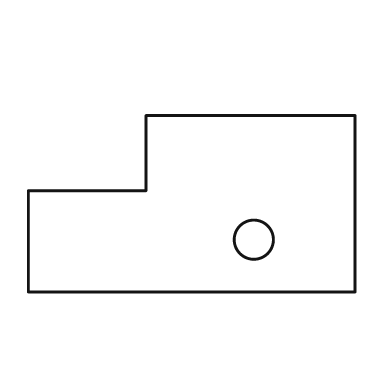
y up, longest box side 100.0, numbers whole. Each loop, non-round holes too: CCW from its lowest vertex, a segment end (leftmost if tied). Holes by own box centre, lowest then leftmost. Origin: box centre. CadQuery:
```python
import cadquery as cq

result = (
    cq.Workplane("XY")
    .moveTo(-50.0, -27.0)
    .lineTo(50.0, -27.0)
    .lineTo(50.0, 27.0)
    .lineTo(-14.0, 27.0)
    .lineTo(-14.0, 4.0)
    .lineTo(-50.0, 4.0)
    .close()
    .moveTo(19.0, -11.0)
    .circle(6.0)
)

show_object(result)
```